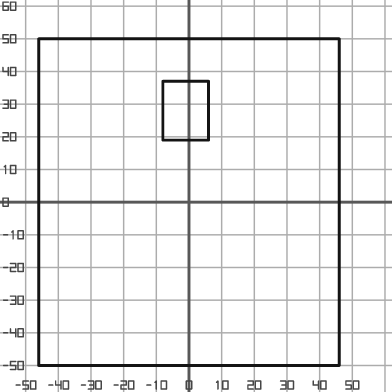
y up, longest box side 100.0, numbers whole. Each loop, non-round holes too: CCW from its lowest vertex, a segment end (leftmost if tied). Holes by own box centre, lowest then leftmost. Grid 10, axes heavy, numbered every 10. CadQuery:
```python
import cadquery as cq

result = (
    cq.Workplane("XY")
    .moveTo(-46.0, -50.0)
    .lineTo(46.0, -50.0)
    .lineTo(46.0, 50.0)
    .lineTo(-46.0, 50.0)
    .close()
    .moveTo(-8.0, 19.0)
    .lineTo(6.0, 19.0)
    .lineTo(6.0, 37.0)
    .lineTo(-8.0, 37.0)
    .close()
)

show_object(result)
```